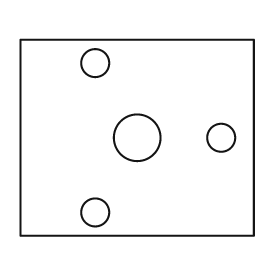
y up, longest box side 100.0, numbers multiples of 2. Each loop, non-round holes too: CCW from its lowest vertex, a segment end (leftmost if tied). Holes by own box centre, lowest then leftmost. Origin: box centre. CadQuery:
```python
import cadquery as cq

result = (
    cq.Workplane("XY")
    .moveTo(-50.0, -42.0)
    .lineTo(50.0, -42.0)
    .lineTo(50.0, 42.0)
    .lineTo(-50.0, 42.0)
    .close()
    .moveTo(-18.0, -32.0)
    .circle(6.0)
    .moveTo(0.0, 0.0)
    .circle(10.0)
    .moveTo(36.0, 0.0)
    .circle(6.0)
    .moveTo(-18.0, 32.0)
    .circle(6.0)
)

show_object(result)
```